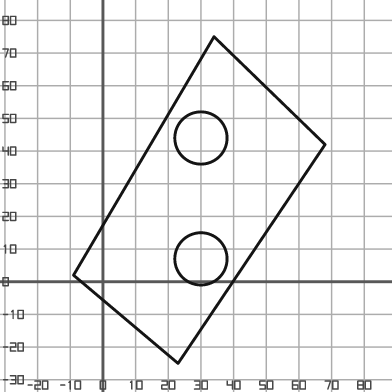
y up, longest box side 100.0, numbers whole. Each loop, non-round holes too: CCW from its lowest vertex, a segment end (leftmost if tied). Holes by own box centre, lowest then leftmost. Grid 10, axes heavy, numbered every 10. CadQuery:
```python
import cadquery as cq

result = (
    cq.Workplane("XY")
    .moveTo(23.0, -25.0)
    .lineTo(68.0, 42.0)
    .lineTo(34.0, 75.0)
    .lineTo(-9.0, 2.0)
    .close()
    .moveTo(30.0, 7.0)
    .circle(8.0)
    .moveTo(30.0, 44.0)
    .circle(8.0)
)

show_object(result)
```